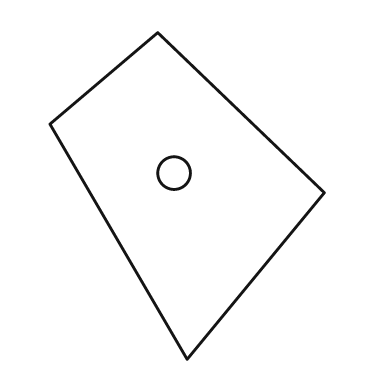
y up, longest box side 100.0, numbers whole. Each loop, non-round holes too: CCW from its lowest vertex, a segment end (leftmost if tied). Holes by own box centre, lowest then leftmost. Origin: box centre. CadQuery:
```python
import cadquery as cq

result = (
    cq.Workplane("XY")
    .moveTo(0.0, -50.0)
    .lineTo(42.0, 1.0)
    .lineTo(-9.0, 50.0)
    .lineTo(-42.0, 22.0)
    .close()
    .moveTo(-4.0, 7.0)
    .circle(5.0)
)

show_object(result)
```